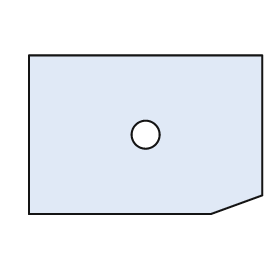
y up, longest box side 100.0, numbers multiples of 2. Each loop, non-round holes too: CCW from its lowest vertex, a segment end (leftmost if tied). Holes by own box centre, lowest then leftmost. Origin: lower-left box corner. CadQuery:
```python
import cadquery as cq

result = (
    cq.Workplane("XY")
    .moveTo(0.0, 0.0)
    .lineTo(78.0, 0.0)
    .lineTo(100.0, 8.0)
    .lineTo(100.0, 68.0)
    .lineTo(0.0, 68.0)
    .close()
    .moveTo(50.0, 34.0)
    .circle(6.0)
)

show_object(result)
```